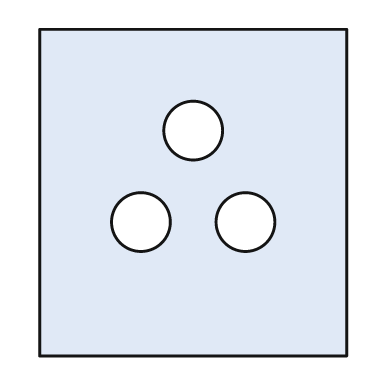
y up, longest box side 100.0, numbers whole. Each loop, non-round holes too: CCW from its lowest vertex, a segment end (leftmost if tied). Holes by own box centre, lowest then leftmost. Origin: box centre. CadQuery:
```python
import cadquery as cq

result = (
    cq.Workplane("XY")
    .moveTo(-47.0, -50.0)
    .lineTo(47.0, -50.0)
    .lineTo(47.0, 50.0)
    .lineTo(-47.0, 50.0)
    .close()
    .moveTo(-16.0, -9.0)
    .circle(9.0)
    .moveTo(16.0, -9.0)
    .circle(9.0)
    .moveTo(0.0, 19.0)
    .circle(9.0)
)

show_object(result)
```